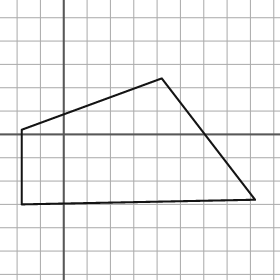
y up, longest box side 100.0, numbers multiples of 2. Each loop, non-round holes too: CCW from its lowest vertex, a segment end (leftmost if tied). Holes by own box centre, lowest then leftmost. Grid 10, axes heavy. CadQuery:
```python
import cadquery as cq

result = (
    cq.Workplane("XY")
    .moveTo(-18.0, -30.0)
    .lineTo(82.0, -28.0)
    .lineTo(42.0, 24.0)
    .lineTo(-18.0, 2.0)
    .close()
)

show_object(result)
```